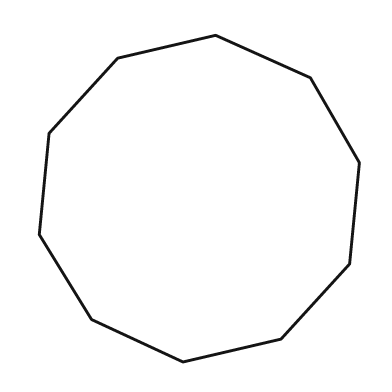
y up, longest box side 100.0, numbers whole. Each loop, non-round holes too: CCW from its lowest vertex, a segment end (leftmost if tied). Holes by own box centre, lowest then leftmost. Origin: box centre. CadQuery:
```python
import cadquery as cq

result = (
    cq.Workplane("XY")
    .moveTo(-5.0, -50.0)
    .lineTo(25.0, -43.0)
    .lineTo(46.0, -20.0)
    .lineTo(49.0, 11.0)
    .lineTo(34.0, 37.0)
    .lineTo(5.0, 50.0)
    .lineTo(-25.0, 43.0)
    .lineTo(-46.0, 20.0)
    .lineTo(-49.0, -11.0)
    .lineTo(-33.0, -37.0)
    .close()
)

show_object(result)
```